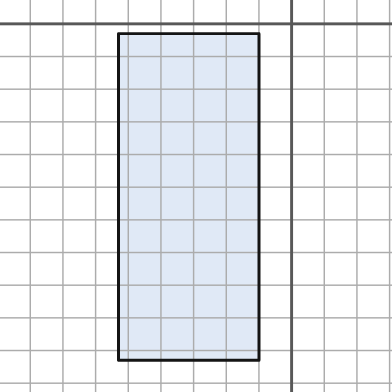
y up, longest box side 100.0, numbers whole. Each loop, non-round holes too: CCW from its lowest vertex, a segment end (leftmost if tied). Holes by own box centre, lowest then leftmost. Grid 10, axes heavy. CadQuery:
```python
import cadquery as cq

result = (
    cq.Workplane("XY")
    .moveTo(-53.0, -103.0)
    .lineTo(-10.0, -103.0)
    .lineTo(-10.0, -3.0)
    .lineTo(-53.0, -3.0)
    .close()
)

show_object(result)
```